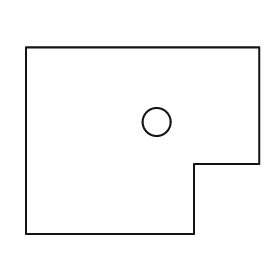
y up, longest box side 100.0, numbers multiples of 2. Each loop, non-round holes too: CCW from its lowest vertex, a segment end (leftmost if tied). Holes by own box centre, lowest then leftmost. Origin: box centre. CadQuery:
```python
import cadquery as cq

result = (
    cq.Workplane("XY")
    .moveTo(-50.0, -40.0)
    .lineTo(22.0, -40.0)
    .lineTo(22.0, -10.0)
    .lineTo(50.0, -10.0)
    .lineTo(50.0, 40.0)
    .lineTo(-50.0, 40.0)
    .close()
    .moveTo(6.0, 8.0)
    .circle(6.0)
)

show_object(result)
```